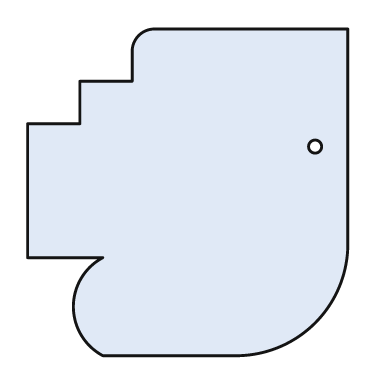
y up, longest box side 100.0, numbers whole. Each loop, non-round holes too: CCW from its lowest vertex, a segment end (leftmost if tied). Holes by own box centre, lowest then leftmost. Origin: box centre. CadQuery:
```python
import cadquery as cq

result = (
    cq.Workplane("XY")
    .moveTo(-26.0, -50.0)
    .lineTo(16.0, -50.0)
    .threePointArc((39.0, -40.0), (49.0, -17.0))
    .lineTo(49.0, 50.0)
    .lineTo(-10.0, 50.0)
    .threePointArc((-15.0, 48.0), (-17.0, 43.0))
    .lineTo(-17.0, 34.0)
    .lineTo(-33.0, 34.0)
    .lineTo(-33.0, 21.0)
    .lineTo(-49.0, 21.0)
    .lineTo(-49.0, -20.0)
    .lineTo(-26.0, -20.0)
    .threePointArc((-35.0, -35.0), (-26.0, -50.0))
    .close()
    .moveTo(39.0, 14.0)
    .circle(2.0)
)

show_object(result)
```